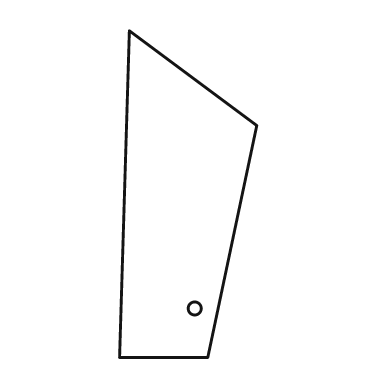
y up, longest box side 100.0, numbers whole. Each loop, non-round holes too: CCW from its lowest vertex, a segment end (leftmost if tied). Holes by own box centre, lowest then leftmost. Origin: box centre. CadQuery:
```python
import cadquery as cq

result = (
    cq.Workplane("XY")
    .moveTo(-21.0, -50.0)
    .lineTo(6.0, -50.0)
    .lineTo(21.0, 21.0)
    .lineTo(-18.0, 50.0)
    .close()
    .moveTo(2.0, -35.0)
    .circle(2.0)
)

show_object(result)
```